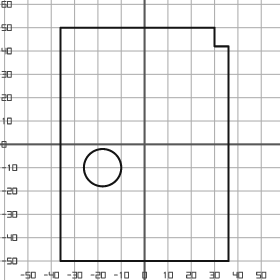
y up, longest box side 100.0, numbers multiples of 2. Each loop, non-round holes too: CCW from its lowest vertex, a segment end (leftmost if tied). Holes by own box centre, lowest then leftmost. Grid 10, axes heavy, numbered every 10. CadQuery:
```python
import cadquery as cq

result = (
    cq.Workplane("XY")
    .moveTo(-36.0, -50.0)
    .lineTo(36.0, -50.0)
    .lineTo(36.0, 42.0)
    .lineTo(30.0, 42.0)
    .lineTo(30.0, 50.0)
    .lineTo(-36.0, 50.0)
    .close()
    .moveTo(-18.0, -10.0)
    .circle(8.0)
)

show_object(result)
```